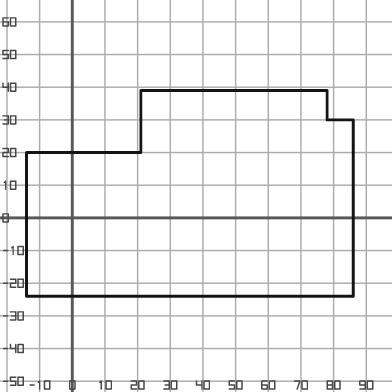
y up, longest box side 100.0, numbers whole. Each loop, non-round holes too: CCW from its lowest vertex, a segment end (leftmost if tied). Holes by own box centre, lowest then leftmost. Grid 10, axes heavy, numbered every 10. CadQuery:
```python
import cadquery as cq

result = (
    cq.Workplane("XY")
    .moveTo(-14.0, -24.0)
    .lineTo(86.0, -24.0)
    .lineTo(86.0, 30.0)
    .lineTo(78.0, 30.0)
    .lineTo(78.0, 39.0)
    .lineTo(21.0, 39.0)
    .lineTo(21.0, 20.0)
    .lineTo(-14.0, 20.0)
    .close()
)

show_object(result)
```